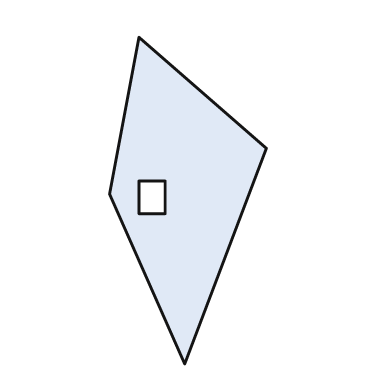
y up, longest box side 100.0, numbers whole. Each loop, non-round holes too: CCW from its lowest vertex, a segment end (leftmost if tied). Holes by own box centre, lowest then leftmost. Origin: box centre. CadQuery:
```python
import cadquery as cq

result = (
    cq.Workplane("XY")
    .moveTo(-1.0, -50.0)
    .lineTo(24.0, 16.0)
    .lineTo(-15.0, 50.0)
    .lineTo(-24.0, 2.0)
    .close()
    .moveTo(-15.0, -4.0)
    .lineTo(-7.0, -4.0)
    .lineTo(-7.0, 6.0)
    .lineTo(-15.0, 6.0)
    .close()
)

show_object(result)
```